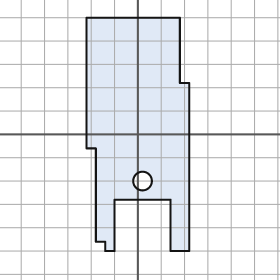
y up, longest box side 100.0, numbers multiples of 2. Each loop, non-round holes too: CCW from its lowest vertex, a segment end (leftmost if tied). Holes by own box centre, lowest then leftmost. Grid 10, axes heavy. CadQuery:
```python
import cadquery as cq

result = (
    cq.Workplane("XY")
    .moveTo(-14.0, -50.0)
    .lineTo(-10.0, -50.0)
    .lineTo(-10.0, -28.0)
    .lineTo(14.0, -28.0)
    .lineTo(14.0, -50.0)
    .lineTo(22.0, -50.0)
    .lineTo(22.0, 22.0)
    .lineTo(18.0, 22.0)
    .lineTo(18.0, 50.0)
    .lineTo(-22.0, 50.0)
    .lineTo(-22.0, -6.0)
    .lineTo(-18.0, -6.0)
    .lineTo(-18.0, -46.0)
    .lineTo(-14.0, -46.0)
    .close()
    .moveTo(2.0, -20.0)
    .circle(4.0)
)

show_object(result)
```